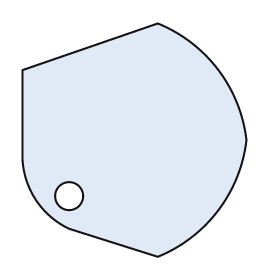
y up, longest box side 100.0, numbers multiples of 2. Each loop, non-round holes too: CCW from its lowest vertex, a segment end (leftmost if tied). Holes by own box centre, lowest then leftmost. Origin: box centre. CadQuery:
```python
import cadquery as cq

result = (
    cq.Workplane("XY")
    .moveTo(10.0, -50.0)
    .threePointArc((36.0, -30.0), (48.0, 0.0))
    .threePointArc((36.0, 30.0), (10.0, 50.0))
    .lineTo(-48.0, 30.0)
    .lineTo(-48.0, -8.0)
    .threePointArc((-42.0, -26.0), (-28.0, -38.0))
    .close()
    .moveTo(-28.0, -24.0)
    .circle(6.0)
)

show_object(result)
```